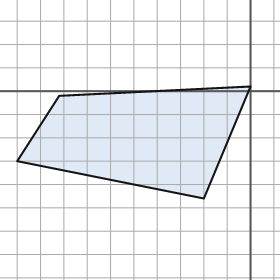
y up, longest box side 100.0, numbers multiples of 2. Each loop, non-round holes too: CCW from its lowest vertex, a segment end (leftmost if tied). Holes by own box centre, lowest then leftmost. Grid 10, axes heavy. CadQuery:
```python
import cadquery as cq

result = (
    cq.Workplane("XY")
    .moveTo(-20.0, -46.0)
    .lineTo(0.0, 2.0)
    .lineTo(-82.0, -2.0)
    .lineTo(-100.0, -30.0)
    .close()
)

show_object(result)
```